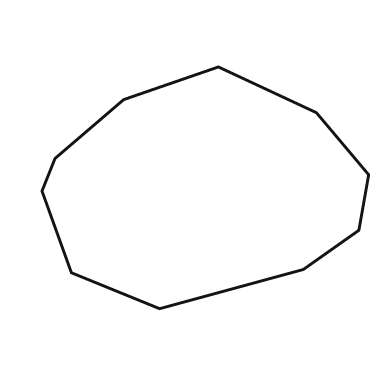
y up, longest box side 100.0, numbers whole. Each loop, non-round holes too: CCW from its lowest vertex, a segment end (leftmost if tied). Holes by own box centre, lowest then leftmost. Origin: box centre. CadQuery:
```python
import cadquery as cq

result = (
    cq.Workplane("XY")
    .moveTo(-14.0, -37.0)
    .lineTo(30.0, -25.0)
    .lineTo(47.0, -13.0)
    .lineTo(50.0, 4.0)
    .lineTo(34.0, 23.0)
    .lineTo(4.0, 37.0)
    .lineTo(-25.0, 27.0)
    .lineTo(-46.0, 9.0)
    .lineTo(-50.0, -1.0)
    .lineTo(-41.0, -26.0)
    .close()
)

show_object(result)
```